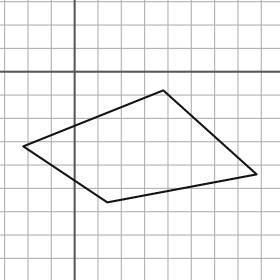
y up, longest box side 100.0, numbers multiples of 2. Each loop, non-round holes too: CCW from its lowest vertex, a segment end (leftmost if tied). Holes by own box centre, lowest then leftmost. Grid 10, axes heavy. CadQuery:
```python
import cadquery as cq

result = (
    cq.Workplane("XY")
    .moveTo(14.0, -56.0)
    .lineTo(78.0, -44.0)
    .lineTo(38.0, -8.0)
    .lineTo(-22.0, -32.0)
    .close()
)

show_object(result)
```